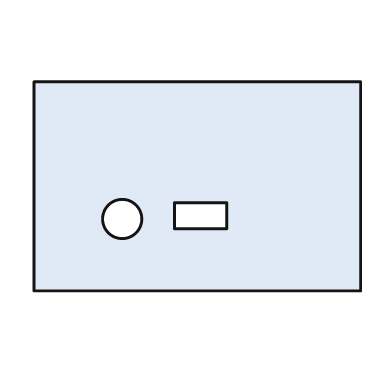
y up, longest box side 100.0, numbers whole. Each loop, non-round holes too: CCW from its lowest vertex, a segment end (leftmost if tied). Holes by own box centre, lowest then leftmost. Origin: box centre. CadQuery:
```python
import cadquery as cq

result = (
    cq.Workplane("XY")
    .moveTo(-50.0, -32.0)
    .lineTo(50.0, -32.0)
    .lineTo(50.0, 32.0)
    .lineTo(-50.0, 32.0)
    .close()
    .moveTo(-23.0, -10.0)
    .circle(6.0)
    .moveTo(-7.0, -13.0)
    .lineTo(9.0, -13.0)
    .lineTo(9.0, -5.0)
    .lineTo(-7.0, -5.0)
    .close()
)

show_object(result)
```